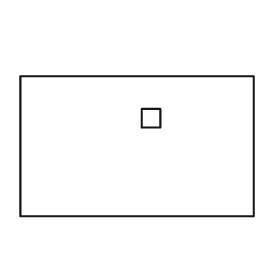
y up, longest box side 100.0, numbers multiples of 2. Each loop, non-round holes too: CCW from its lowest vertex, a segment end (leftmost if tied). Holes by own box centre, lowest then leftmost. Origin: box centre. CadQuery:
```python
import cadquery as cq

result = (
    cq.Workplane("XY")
    .moveTo(-50.0, -30.0)
    .lineTo(50.0, -30.0)
    .lineTo(50.0, 30.0)
    .lineTo(-50.0, 30.0)
    .close()
    .moveTo(2.0, 8.0)
    .lineTo(10.0, 8.0)
    .lineTo(10.0, 16.0)
    .lineTo(2.0, 16.0)
    .close()
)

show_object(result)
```